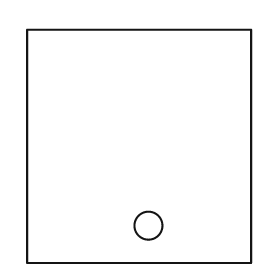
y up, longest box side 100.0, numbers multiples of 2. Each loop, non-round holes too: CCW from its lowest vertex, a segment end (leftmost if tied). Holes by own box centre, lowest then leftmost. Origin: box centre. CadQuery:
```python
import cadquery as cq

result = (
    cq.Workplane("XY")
    .moveTo(-48.0, -50.0)
    .lineTo(48.0, -50.0)
    .lineTo(48.0, 50.0)
    .lineTo(-48.0, 50.0)
    .close()
    .moveTo(4.0, -34.0)
    .circle(6.0)
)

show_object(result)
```